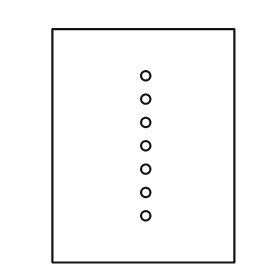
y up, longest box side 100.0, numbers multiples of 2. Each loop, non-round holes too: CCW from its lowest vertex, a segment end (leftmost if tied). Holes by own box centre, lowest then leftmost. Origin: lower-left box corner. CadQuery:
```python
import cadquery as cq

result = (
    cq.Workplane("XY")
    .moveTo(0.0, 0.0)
    .lineTo(78.0, 0.0)
    .lineTo(78.0, 100.0)
    .lineTo(0.0, 100.0)
    .close()
    .moveTo(40.0, 20.0)
    .circle(2.0)
    .moveTo(40.0, 30.0)
    .circle(2.0)
    .moveTo(40.0, 40.0)
    .circle(2.0)
    .moveTo(40.0, 50.0)
    .circle(2.0)
    .moveTo(40.0, 60.0)
    .circle(2.0)
    .moveTo(40.0, 70.0)
    .circle(2.0)
    .moveTo(40.0, 80.0)
    .circle(2.0)
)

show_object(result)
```